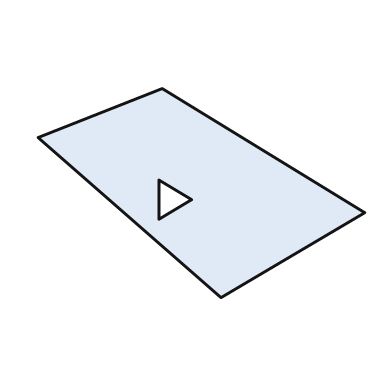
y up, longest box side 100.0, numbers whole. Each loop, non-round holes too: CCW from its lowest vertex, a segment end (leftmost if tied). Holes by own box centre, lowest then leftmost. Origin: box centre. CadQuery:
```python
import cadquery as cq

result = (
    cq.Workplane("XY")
    .moveTo(6.0, -32.0)
    .lineTo(50.0, -6.0)
    .lineTo(-12.0, 32.0)
    .lineTo(-50.0, 17.0)
    .close()
    .moveTo(-13.0, -8.0)
    .lineTo(-3.0, -2.0)
    .lineTo(-13.0, 4.0)
    .close()
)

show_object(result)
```